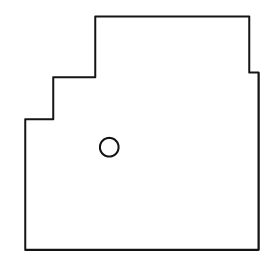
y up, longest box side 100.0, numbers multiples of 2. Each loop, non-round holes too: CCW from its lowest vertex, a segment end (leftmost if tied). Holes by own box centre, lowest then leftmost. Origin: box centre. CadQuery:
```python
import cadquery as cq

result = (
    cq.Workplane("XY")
    .moveTo(-50.0, -50.0)
    .lineTo(50.0, -50.0)
    .lineTo(50.0, 26.0)
    .lineTo(46.0, 26.0)
    .lineTo(46.0, 50.0)
    .lineTo(-20.0, 50.0)
    .lineTo(-20.0, 24.0)
    .lineTo(-38.0, 24.0)
    .lineTo(-38.0, 6.0)
    .lineTo(-50.0, 6.0)
    .close()
    .moveTo(-14.0, -6.0)
    .circle(4.0)
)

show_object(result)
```